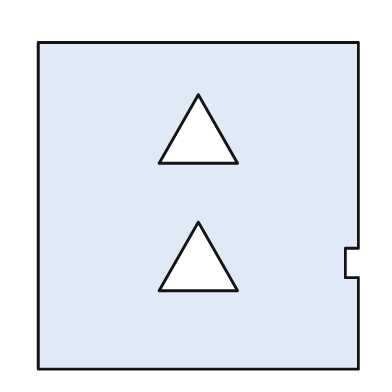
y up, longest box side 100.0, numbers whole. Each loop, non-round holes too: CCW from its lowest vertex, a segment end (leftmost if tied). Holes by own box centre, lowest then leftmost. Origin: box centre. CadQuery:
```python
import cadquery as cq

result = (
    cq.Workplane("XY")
    .moveTo(-49.0, -50.0)
    .lineTo(49.0, -50.0)
    .lineTo(49.0, -22.0)
    .lineTo(45.0, -22.0)
    .lineTo(45.0, -13.0)
    .lineTo(49.0, -13.0)
    .lineTo(49.0, 50.0)
    .lineTo(-49.0, 50.0)
    .close()
    .moveTo(-12.0, -26.0)
    .lineTo(12.0, -26.0)
    .lineTo(0.0, -5.0)
    .close()
    .moveTo(-12.0, 13.0)
    .lineTo(12.0, 13.0)
    .lineTo(0.0, 34.0)
    .close()
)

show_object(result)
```